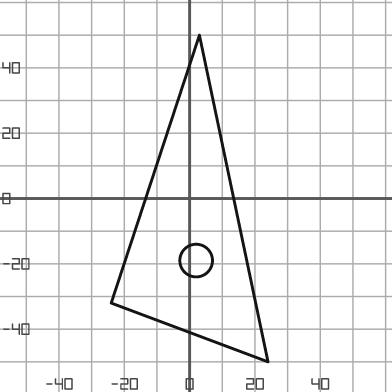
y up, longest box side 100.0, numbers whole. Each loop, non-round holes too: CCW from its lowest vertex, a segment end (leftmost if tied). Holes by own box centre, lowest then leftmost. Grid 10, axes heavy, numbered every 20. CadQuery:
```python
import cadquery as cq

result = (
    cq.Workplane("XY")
    .moveTo(24.0, -50.0)
    .lineTo(3.0, 50.0)
    .lineTo(-24.0, -32.0)
    .close()
    .moveTo(2.0, -19.0)
    .circle(5.0)
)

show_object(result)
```